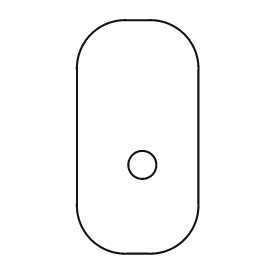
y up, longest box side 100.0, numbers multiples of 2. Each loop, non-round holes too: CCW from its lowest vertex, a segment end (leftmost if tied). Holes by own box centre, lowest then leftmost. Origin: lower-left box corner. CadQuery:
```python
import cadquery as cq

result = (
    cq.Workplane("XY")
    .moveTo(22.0, 0.0)
    .lineTo(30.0, 0.0)
    .threePointArc((46.0, 6.0), (52.0, 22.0))
    .lineTo(52.0, 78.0)
    .threePointArc((46.0, 94.0), (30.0, 100.0))
    .lineTo(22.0, 100.0)
    .threePointArc((6.0, 94.0), (0.0, 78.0))
    .lineTo(0.0, 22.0)
    .threePointArc((6.0, 6.0), (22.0, 0.0))
    .close()
    .moveTo(28.0, 38.0)
    .circle(6.0)
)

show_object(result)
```